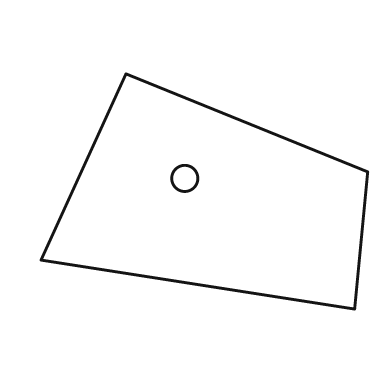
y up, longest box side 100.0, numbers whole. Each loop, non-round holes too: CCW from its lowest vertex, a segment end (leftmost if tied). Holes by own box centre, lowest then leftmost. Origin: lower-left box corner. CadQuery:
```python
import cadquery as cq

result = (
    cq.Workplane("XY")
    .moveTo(96.0, 0.0)
    .lineTo(100.0, 42.0)
    .lineTo(26.0, 72.0)
    .lineTo(0.0, 15.0)
    .close()
    .moveTo(44.0, 40.0)
    .circle(4.0)
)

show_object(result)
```